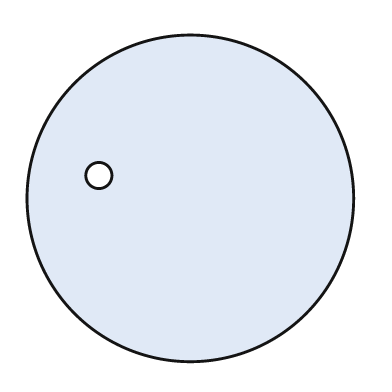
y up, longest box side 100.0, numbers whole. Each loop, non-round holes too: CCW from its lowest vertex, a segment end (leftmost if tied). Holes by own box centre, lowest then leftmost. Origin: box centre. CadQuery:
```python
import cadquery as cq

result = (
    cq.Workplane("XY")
    .moveTo(0.0, 0.0)
    .circle(50.0)
    .moveTo(-28.0, 7.0)
    .circle(4.0)
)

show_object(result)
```